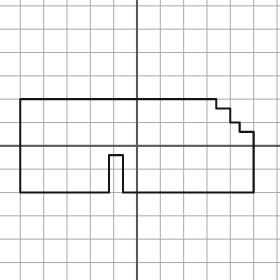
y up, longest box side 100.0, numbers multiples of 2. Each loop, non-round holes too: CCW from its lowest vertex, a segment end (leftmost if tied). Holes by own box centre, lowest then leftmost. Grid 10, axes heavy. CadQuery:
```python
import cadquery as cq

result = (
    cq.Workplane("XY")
    .moveTo(-50.0, -20.0)
    .lineTo(-12.0, -20.0)
    .lineTo(-12.0, -4.0)
    .lineTo(-6.0, -4.0)
    .lineTo(-6.0, -20.0)
    .lineTo(50.0, -20.0)
    .lineTo(50.0, 6.0)
    .lineTo(44.0, 6.0)
    .lineTo(44.0, 10.0)
    .lineTo(40.0, 10.0)
    .lineTo(40.0, 16.0)
    .lineTo(34.0, 16.0)
    .lineTo(34.0, 20.0)
    .lineTo(-50.0, 20.0)
    .close()
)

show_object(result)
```